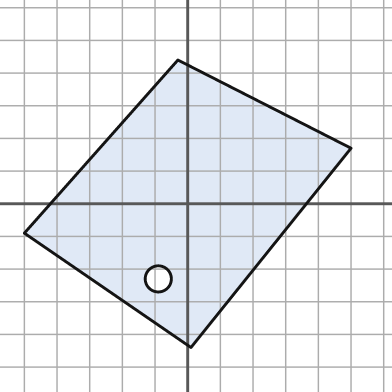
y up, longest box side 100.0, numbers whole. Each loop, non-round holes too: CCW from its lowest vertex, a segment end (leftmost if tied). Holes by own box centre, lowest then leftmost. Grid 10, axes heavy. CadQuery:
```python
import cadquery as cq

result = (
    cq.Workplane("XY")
    .moveTo(1.0, -44.0)
    .lineTo(50.0, 17.0)
    .lineTo(-3.0, 44.0)
    .lineTo(-50.0, -9.0)
    .close()
    .moveTo(-9.0, -23.0)
    .circle(4.0)
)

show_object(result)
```